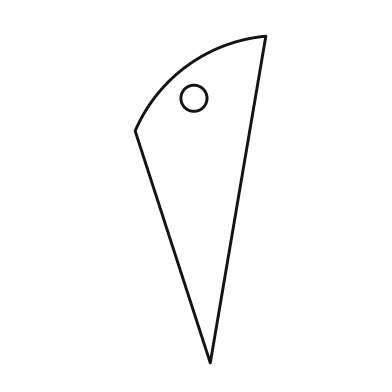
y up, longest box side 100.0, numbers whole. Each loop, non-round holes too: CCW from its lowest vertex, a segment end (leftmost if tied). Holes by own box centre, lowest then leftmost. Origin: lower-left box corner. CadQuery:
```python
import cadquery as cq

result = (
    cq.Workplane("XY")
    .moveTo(23.0, 0.0)
    .lineTo(40.0, 100.0)
    .threePointArc((16.0, 91.0), (0.0, 71.0))
    .close()
    .moveTo(18.0, 81.0)
    .circle(4.0)
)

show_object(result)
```